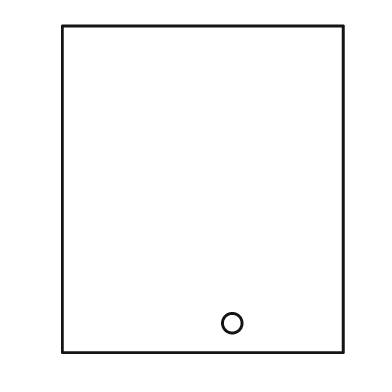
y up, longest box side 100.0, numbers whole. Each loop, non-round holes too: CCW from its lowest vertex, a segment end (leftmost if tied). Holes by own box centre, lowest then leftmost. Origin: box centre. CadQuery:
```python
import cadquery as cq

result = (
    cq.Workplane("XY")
    .moveTo(-43.0, -50.0)
    .lineTo(43.0, -50.0)
    .lineTo(43.0, 50.0)
    .lineTo(-43.0, 50.0)
    .close()
    .moveTo(9.0, -41.0)
    .circle(3.0)
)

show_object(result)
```